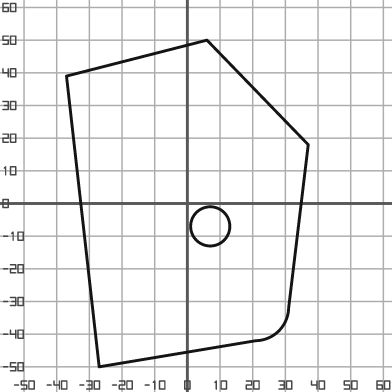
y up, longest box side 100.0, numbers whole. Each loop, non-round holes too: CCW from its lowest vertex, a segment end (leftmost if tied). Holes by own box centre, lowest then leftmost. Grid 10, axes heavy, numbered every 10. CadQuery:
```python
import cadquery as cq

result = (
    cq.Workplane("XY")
    .moveTo(-27.0, -50.0)
    .lineTo(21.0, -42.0)
    .threePointArc((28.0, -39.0), (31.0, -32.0))
    .lineTo(37.0, 18.0)
    .lineTo(6.0, 50.0)
    .lineTo(-37.0, 39.0)
    .close()
    .moveTo(7.0, -7.0)
    .circle(6.0)
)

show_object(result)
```